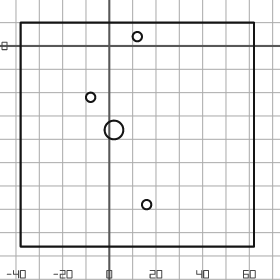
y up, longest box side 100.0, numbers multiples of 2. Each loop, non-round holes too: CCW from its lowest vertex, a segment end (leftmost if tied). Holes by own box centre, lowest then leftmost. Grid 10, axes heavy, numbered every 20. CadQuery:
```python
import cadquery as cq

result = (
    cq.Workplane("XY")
    .moveTo(-38.0, -86.0)
    .lineTo(62.0, -86.0)
    .lineTo(62.0, 10.0)
    .lineTo(-38.0, 10.0)
    .close()
    .moveTo(16.0, -68.0)
    .circle(2.0)
    .moveTo(2.0, -36.0)
    .circle(4.0)
    .moveTo(-8.0, -22.0)
    .circle(2.0)
    .moveTo(12.0, 4.0)
    .circle(2.0)
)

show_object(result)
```